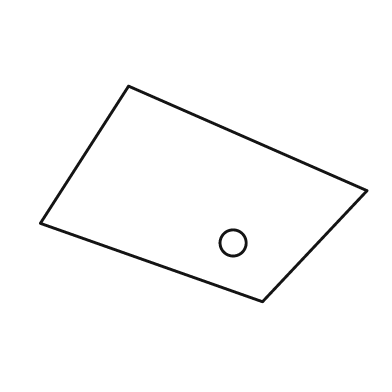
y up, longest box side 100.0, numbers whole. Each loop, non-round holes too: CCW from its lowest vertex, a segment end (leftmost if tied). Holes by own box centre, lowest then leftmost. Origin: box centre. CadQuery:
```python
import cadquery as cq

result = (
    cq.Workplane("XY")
    .moveTo(18.0, -33.0)
    .lineTo(50.0, 1.0)
    .lineTo(-23.0, 33.0)
    .lineTo(-50.0, -9.0)
    .close()
    .moveTo(9.0, -15.0)
    .circle(4.0)
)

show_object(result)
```